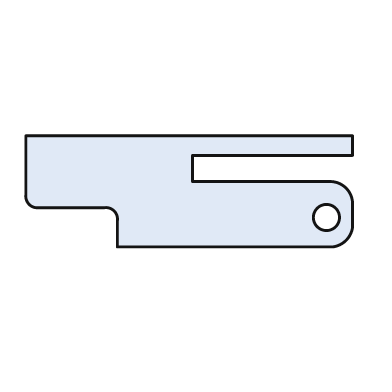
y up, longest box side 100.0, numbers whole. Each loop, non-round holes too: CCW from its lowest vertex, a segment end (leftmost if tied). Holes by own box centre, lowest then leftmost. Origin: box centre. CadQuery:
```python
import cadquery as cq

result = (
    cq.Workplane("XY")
    .moveTo(-22.0, -17.0)
    .lineTo(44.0, -17.0)
    .threePointArc((48.0, -15.0), (50.0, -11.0))
    .lineTo(50.0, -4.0)
    .threePointArc((48.0, 1.0), (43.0, 3.0))
    .lineTo(1.0, 3.0)
    .lineTo(1.0, 11.0)
    .lineTo(50.0, 11.0)
    .lineTo(50.0, 17.0)
    .lineTo(-50.0, 17.0)
    .lineTo(-50.0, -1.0)
    .threePointArc((-49.0, -4.0), (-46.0, -5.0))
    .lineTo(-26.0, -5.0)
    .threePointArc((-23.0, -6.0), (-22.0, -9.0))
    .close()
    .moveTo(42.0, -8.0)
    .circle(4.0)
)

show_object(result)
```